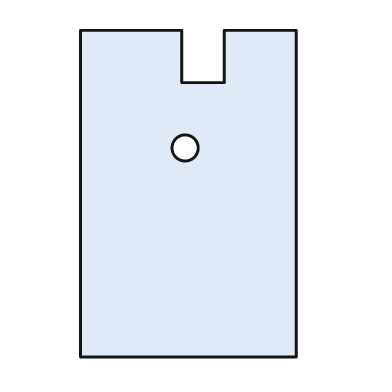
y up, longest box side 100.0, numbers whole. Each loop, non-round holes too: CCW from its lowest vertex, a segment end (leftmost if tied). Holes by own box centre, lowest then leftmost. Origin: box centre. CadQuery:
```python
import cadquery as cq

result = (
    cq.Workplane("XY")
    .moveTo(-33.0, -50.0)
    .lineTo(33.0, -50.0)
    .lineTo(33.0, 50.0)
    .lineTo(11.0, 50.0)
    .lineTo(11.0, 34.0)
    .lineTo(-2.0, 34.0)
    .lineTo(-2.0, 50.0)
    .lineTo(-33.0, 50.0)
    .close()
    .moveTo(-1.0, 14.0)
    .circle(4.0)
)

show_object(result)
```